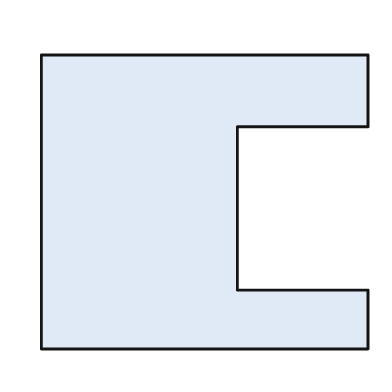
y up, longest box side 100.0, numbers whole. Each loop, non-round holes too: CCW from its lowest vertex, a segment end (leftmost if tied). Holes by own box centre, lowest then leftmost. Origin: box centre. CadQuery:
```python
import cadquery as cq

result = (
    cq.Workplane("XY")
    .moveTo(-50.0, -45.0)
    .lineTo(50.0, -45.0)
    .lineTo(50.0, -27.0)
    .lineTo(10.0, -27.0)
    .lineTo(10.0, 23.0)
    .lineTo(50.0, 23.0)
    .lineTo(50.0, 45.0)
    .lineTo(-50.0, 45.0)
    .close()
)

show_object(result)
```